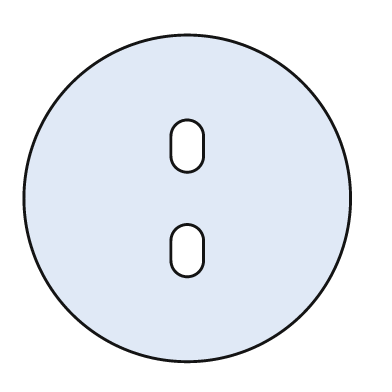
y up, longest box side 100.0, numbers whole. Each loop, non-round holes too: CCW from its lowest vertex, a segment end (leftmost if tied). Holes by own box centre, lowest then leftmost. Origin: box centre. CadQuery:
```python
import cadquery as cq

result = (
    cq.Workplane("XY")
    .moveTo(0.0, 0.0)
    .circle(50.0)
    .moveTo(-5.0, -19.0)
    .threePointArc((0.0, -24.0), (5.0, -19.0))
    .lineTo(5.0, -13.0)
    .threePointArc((0.0, -8.0), (-5.0, -13.0))
    .close()
    .moveTo(-5.0, 13.0)
    .threePointArc((0.0, 8.0), (5.0, 13.0))
    .lineTo(5.0, 19.0)
    .threePointArc((0.0, 24.0), (-5.0, 19.0))
    .close()
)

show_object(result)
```